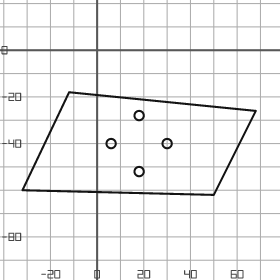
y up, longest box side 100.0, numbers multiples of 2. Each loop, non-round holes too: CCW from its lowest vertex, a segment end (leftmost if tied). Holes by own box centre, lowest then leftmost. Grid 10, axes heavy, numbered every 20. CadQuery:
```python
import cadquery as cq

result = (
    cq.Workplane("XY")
    .moveTo(50.0, -62.0)
    .lineTo(68.0, -26.0)
    .lineTo(-12.0, -18.0)
    .lineTo(-32.0, -60.0)
    .close()
    .moveTo(18.0, -52.0)
    .circle(2.0)
    .moveTo(6.0, -40.0)
    .circle(2.0)
    .moveTo(30.0, -40.0)
    .circle(2.0)
    .moveTo(18.0, -28.0)
    .circle(2.0)
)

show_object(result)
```